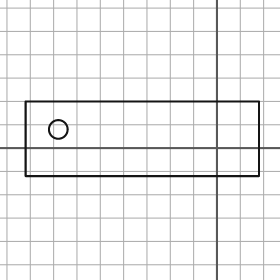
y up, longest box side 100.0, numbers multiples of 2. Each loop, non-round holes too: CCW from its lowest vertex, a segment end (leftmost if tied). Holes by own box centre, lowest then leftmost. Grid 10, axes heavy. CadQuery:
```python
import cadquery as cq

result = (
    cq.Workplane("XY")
    .moveTo(-82.0, -12.0)
    .lineTo(18.0, -12.0)
    .lineTo(18.0, 20.0)
    .lineTo(-82.0, 20.0)
    .close()
    .moveTo(-68.0, 8.0)
    .circle(4.0)
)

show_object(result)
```